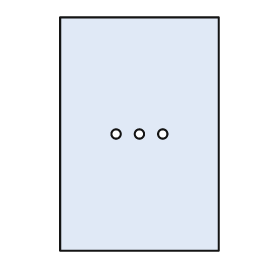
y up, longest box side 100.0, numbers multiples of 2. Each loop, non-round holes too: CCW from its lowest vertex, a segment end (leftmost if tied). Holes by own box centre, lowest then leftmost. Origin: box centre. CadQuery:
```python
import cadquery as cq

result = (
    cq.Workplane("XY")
    .moveTo(-34.0, -50.0)
    .lineTo(34.0, -50.0)
    .lineTo(34.0, 50.0)
    .lineTo(-34.0, 50.0)
    .close()
    .moveTo(-10.0, 0.0)
    .circle(2.0)
    .moveTo(0.0, 0.0)
    .circle(2.0)
    .moveTo(10.0, 0.0)
    .circle(2.0)
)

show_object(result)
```